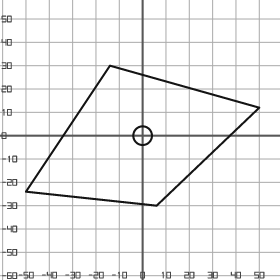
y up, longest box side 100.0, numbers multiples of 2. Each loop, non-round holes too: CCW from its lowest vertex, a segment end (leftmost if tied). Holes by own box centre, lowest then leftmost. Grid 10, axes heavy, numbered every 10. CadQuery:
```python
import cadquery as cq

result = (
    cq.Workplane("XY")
    .moveTo(6.0, -30.0)
    .lineTo(50.0, 12.0)
    .lineTo(-14.0, 30.0)
    .lineTo(-50.0, -24.0)
    .close()
    .moveTo(0.0, 0.0)
    .circle(4.0)
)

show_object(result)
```